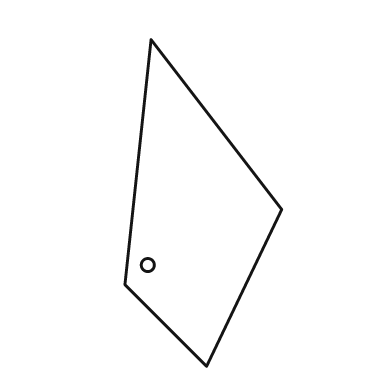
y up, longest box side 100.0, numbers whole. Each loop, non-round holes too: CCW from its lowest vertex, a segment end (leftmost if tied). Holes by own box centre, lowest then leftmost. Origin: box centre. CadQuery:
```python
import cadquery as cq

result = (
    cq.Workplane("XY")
    .moveTo(1.0, -50.0)
    .lineTo(24.0, -2.0)
    .lineTo(-16.0, 50.0)
    .lineTo(-24.0, -25.0)
    .close()
    .moveTo(-17.0, -19.0)
    .circle(2.0)
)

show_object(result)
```